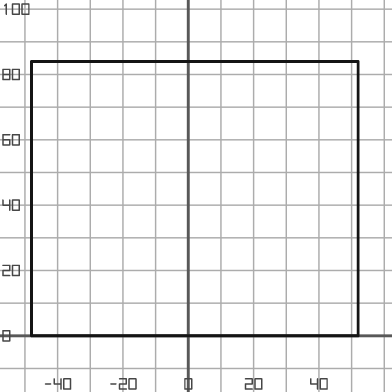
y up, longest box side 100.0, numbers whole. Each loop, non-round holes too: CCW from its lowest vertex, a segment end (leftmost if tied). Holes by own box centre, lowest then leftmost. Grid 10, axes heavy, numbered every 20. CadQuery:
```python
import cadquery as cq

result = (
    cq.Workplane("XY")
    .moveTo(-48.0, 0.0)
    .lineTo(52.0, 0.0)
    .lineTo(52.0, 84.0)
    .lineTo(-48.0, 84.0)
    .close()
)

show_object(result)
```